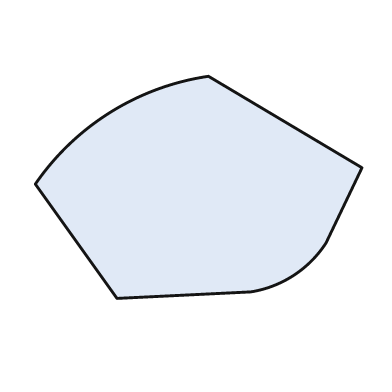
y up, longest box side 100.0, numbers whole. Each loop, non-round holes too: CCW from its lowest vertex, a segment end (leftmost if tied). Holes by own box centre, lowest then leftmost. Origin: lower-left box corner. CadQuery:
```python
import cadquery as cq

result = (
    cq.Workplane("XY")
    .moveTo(25.0, 0.0)
    .lineTo(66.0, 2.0)
    .threePointArc((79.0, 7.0), (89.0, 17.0))
    .lineTo(100.0, 40.0)
    .lineTo(53.0, 68.0)
    .threePointArc((23.0, 57.0), (0.0, 35.0))
    .close()
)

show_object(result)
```